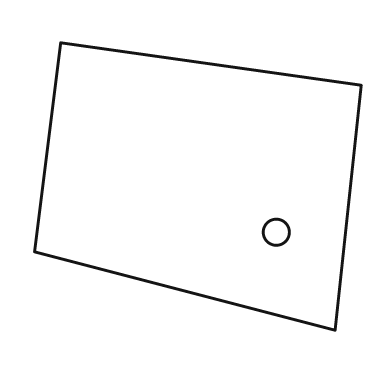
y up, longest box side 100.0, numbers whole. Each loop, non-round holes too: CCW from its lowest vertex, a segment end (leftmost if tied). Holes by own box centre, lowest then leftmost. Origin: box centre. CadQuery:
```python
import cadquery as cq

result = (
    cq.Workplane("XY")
    .moveTo(42.0, -44.0)
    .lineTo(50.0, 31.0)
    .lineTo(-42.0, 44.0)
    .lineTo(-50.0, -20.0)
    .close()
    .moveTo(24.0, -14.0)
    .circle(4.0)
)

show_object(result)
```